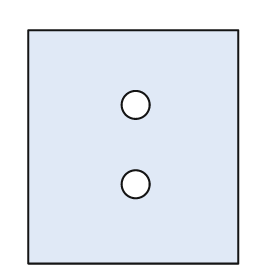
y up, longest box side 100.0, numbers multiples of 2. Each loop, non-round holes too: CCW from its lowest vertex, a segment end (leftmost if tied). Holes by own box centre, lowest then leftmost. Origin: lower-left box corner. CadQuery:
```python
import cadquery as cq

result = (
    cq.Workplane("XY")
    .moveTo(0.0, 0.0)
    .lineTo(90.0, 0.0)
    .lineTo(90.0, 100.0)
    .lineTo(0.0, 100.0)
    .close()
    .moveTo(46.0, 34.0)
    .circle(6.0)
    .moveTo(46.0, 68.0)
    .circle(6.0)
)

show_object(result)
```